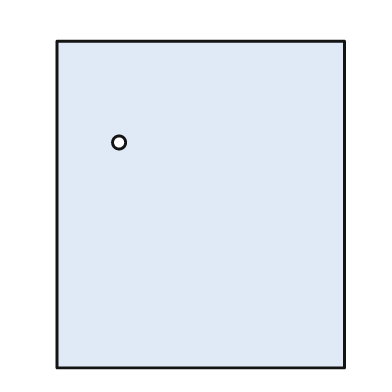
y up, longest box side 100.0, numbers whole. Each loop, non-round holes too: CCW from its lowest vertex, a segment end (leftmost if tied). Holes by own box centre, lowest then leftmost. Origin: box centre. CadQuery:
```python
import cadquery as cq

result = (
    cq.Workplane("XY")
    .moveTo(-44.0, -50.0)
    .lineTo(44.0, -50.0)
    .lineTo(44.0, 50.0)
    .lineTo(-44.0, 50.0)
    .close()
    .moveTo(-25.0, 19.0)
    .circle(2.0)
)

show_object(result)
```